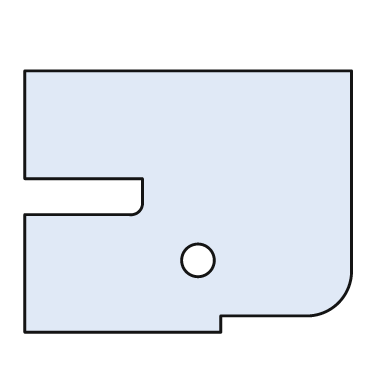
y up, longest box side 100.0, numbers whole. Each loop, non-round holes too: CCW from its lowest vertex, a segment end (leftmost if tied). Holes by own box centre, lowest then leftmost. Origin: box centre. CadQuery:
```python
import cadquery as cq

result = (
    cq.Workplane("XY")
    .moveTo(-50.0, -40.0)
    .lineTo(10.0, -40.0)
    .lineTo(10.0, -35.0)
    .lineTo(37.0, -35.0)
    .threePointArc((46.0, -31.0), (50.0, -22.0))
    .lineTo(50.0, 40.0)
    .lineTo(-50.0, 40.0)
    .lineTo(-50.0, 7.0)
    .lineTo(-14.0, 7.0)
    .lineTo(-14.0, 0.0)
    .threePointArc((-15.0, -3.0), (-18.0, -4.0))
    .lineTo(-50.0, -4.0)
    .close()
    .moveTo(3.0, -18.0)
    .circle(5.0)
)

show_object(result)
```